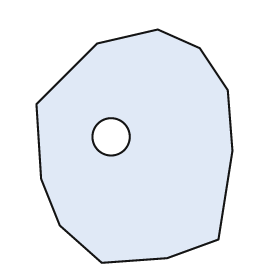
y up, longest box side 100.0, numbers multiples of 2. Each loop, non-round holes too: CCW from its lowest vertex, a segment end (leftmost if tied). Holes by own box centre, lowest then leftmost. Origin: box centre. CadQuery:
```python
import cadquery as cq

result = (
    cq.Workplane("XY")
    .moveTo(-14.0, -50.0)
    .lineTo(14.0, -48.0)
    .lineTo(36.0, -40.0)
    .lineTo(42.0, -2.0)
    .lineTo(40.0, 24.0)
    .lineTo(28.0, 42.0)
    .lineTo(10.0, 50.0)
    .lineTo(-16.0, 44.0)
    .lineTo(-42.0, 18.0)
    .lineTo(-40.0, -14.0)
    .lineTo(-32.0, -34.0)
    .close()
    .moveTo(-10.0, 4.0)
    .circle(8.0)
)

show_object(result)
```